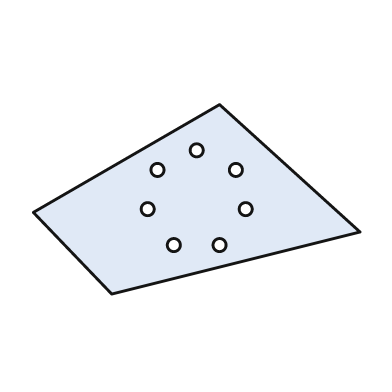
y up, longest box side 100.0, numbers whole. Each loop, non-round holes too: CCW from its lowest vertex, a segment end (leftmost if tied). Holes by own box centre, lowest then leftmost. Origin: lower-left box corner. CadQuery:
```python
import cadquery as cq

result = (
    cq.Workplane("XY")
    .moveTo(24.0, 0.0)
    .lineTo(100.0, 19.0)
    .lineTo(57.0, 58.0)
    .lineTo(0.0, 25.0)
    .close()
    .moveTo(43.0, 15.0)
    .circle(2.0)
    .moveTo(57.0, 15.0)
    .circle(2.0)
    .moveTo(35.0, 26.0)
    .circle(2.0)
    .moveTo(65.0, 26.0)
    .circle(2.0)
    .moveTo(38.0, 38.0)
    .circle(2.0)
    .moveTo(62.0, 38.0)
    .circle(2.0)
    .moveTo(50.0, 44.0)
    .circle(2.0)
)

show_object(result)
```